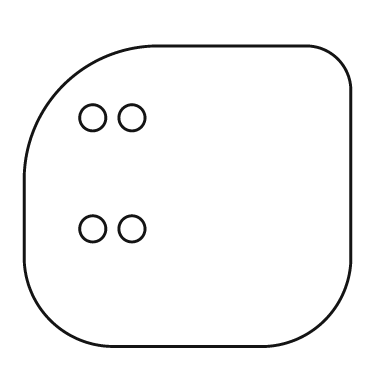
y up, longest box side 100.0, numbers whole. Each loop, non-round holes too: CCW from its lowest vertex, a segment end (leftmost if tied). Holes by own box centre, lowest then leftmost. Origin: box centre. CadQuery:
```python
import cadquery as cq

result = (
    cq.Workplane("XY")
    .moveTo(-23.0, -46.0)
    .lineTo(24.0, -46.0)
    .threePointArc((42.0, -38.0), (50.0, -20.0))
    .lineTo(50.0, 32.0)
    .threePointArc((46.0, 42.0), (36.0, 46.0))
    .lineTo(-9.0, 46.0)
    .threePointArc((-38.0, 34.0), (-50.0, 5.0))
    .lineTo(-50.0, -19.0)
    .threePointArc((-42.0, -38.0), (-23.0, -46.0))
    .close()
    .moveTo(-29.0, -10.0)
    .circle(4.0)
    .moveTo(-17.0, -10.0)
    .circle(4.0)
    .moveTo(-29.0, 24.0)
    .circle(4.0)
    .moveTo(-17.0, 24.0)
    .circle(4.0)
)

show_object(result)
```